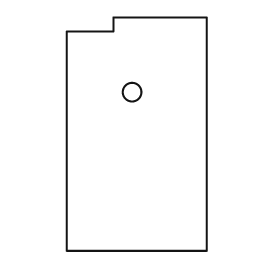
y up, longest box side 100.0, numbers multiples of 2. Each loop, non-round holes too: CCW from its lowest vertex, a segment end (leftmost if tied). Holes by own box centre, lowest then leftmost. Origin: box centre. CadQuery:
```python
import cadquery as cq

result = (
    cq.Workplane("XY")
    .moveTo(-30.0, -50.0)
    .lineTo(30.0, -50.0)
    .lineTo(30.0, 50.0)
    .lineTo(-10.0, 50.0)
    .lineTo(-10.0, 44.0)
    .lineTo(-30.0, 44.0)
    .close()
    .moveTo(-2.0, 18.0)
    .circle(4.0)
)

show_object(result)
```